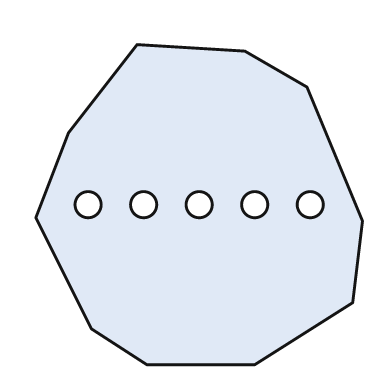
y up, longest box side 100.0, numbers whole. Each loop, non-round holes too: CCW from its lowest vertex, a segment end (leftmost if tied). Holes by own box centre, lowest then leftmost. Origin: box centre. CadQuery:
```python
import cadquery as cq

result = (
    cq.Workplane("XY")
    .moveTo(-16.0, -49.0)
    .lineTo(17.0, -49.0)
    .lineTo(47.0, -30.0)
    .lineTo(50.0, -5.0)
    .lineTo(33.0, 36.0)
    .lineTo(14.0, 47.0)
    .lineTo(-19.0, 49.0)
    .lineTo(-40.0, 22.0)
    .lineTo(-50.0, -4.0)
    .lineTo(-33.0, -38.0)
    .close()
    .moveTo(-34.0, 0.0)
    .circle(4.0)
    .moveTo(-17.0, 0.0)
    .circle(4.0)
    .moveTo(0.0, 0.0)
    .circle(4.0)
    .moveTo(17.0, 0.0)
    .circle(4.0)
    .moveTo(34.0, 0.0)
    .circle(4.0)
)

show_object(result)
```